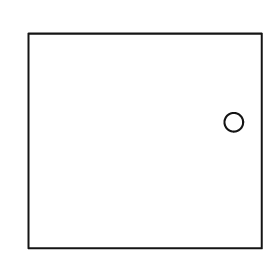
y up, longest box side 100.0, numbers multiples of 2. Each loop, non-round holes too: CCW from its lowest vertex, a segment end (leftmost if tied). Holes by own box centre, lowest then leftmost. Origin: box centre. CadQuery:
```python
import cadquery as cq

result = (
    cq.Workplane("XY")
    .moveTo(-50.0, -46.0)
    .lineTo(50.0, -46.0)
    .lineTo(50.0, 46.0)
    .lineTo(-50.0, 46.0)
    .close()
    .moveTo(38.0, 8.0)
    .circle(4.0)
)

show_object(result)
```